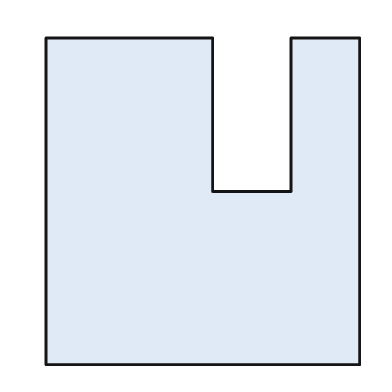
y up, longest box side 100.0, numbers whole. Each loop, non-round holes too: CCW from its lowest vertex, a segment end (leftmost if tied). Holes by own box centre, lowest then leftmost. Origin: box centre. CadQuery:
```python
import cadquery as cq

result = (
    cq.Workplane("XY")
    .moveTo(-48.0, -50.0)
    .lineTo(48.0, -50.0)
    .lineTo(48.0, 50.0)
    .lineTo(27.0, 50.0)
    .lineTo(27.0, 3.0)
    .lineTo(3.0, 3.0)
    .lineTo(3.0, 50.0)
    .lineTo(-48.0, 50.0)
    .close()
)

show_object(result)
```